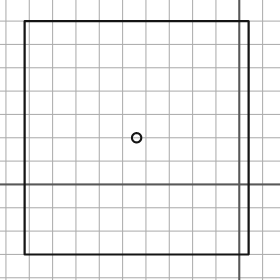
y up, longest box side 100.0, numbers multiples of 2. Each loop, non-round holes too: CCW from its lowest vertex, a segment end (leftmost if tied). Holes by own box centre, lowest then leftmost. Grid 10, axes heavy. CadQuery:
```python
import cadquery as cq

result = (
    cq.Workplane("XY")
    .moveTo(-92.0, -30.0)
    .lineTo(4.0, -30.0)
    .lineTo(4.0, 70.0)
    .lineTo(-92.0, 70.0)
    .close()
    .moveTo(-44.0, 20.0)
    .circle(2.0)
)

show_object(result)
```